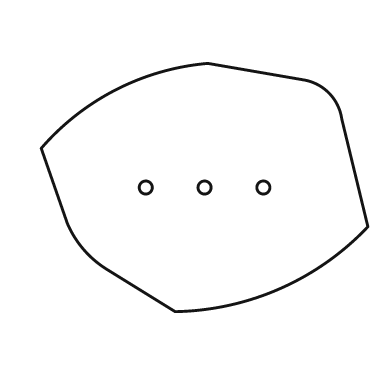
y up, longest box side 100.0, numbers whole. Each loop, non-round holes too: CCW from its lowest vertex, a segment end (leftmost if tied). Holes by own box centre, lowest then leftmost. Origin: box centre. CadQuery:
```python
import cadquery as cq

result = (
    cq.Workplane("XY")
    .moveTo(-9.0, -38.0)
    .threePointArc((23.0, -31.0), (50.0, -12.0))
    .lineTo(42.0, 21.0)
    .threePointArc((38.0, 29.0), (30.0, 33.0))
    .lineTo(1.0, 38.0)
    .threePointArc((-27.0, 30.0), (-50.0, 12.0))
    .lineTo(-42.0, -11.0)
    .threePointArc((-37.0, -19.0), (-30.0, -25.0))
    .close()
    .moveTo(-18.0, 0.0)
    .circle(2.0)
    .moveTo(0.0, 0.0)
    .circle(2.0)
    .moveTo(18.0, 0.0)
    .circle(2.0)
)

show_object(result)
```